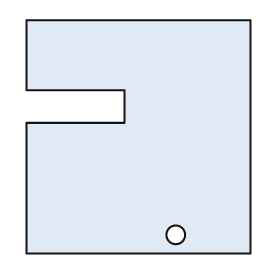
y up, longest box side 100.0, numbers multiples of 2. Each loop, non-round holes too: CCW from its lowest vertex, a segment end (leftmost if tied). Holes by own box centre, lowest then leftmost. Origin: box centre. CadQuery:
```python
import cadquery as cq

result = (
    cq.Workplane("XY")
    .moveTo(-48.0, -50.0)
    .lineTo(48.0, -50.0)
    .lineTo(48.0, 50.0)
    .lineTo(-48.0, 50.0)
    .lineTo(-48.0, 20.0)
    .lineTo(-6.0, 20.0)
    .lineTo(-6.0, 6.0)
    .lineTo(-48.0, 6.0)
    .close()
    .moveTo(16.0, -42.0)
    .circle(4.0)
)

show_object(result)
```